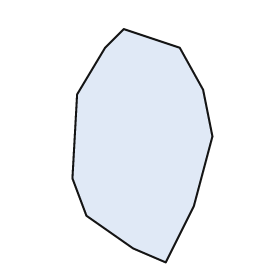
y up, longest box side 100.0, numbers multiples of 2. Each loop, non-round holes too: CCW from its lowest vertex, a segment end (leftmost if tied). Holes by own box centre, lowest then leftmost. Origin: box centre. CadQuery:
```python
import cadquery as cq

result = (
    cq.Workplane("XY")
    .moveTo(10.0, -50.0)
    .lineTo(22.0, -26.0)
    .lineTo(30.0, 4.0)
    .lineTo(26.0, 24.0)
    .lineTo(16.0, 42.0)
    .lineTo(-8.0, 50.0)
    .lineTo(-16.0, 42.0)
    .lineTo(-28.0, 22.0)
    .lineTo(-30.0, -14.0)
    .lineTo(-24.0, -30.0)
    .lineTo(-4.0, -44.0)
    .close()
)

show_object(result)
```